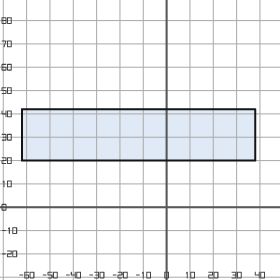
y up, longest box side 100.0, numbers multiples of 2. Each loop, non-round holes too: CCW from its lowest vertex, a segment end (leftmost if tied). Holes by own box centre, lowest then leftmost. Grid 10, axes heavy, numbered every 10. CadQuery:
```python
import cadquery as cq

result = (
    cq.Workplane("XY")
    .moveTo(-62.0, 20.0)
    .lineTo(38.0, 20.0)
    .lineTo(38.0, 42.0)
    .lineTo(-62.0, 42.0)
    .close()
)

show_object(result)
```